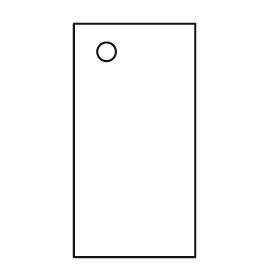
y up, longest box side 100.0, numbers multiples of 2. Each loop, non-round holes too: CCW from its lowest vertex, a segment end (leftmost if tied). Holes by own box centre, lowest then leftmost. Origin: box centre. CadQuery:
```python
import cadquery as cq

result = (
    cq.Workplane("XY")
    .moveTo(-26.0, -50.0)
    .lineTo(26.0, -50.0)
    .lineTo(26.0, 50.0)
    .lineTo(-26.0, 50.0)
    .close()
    .moveTo(-12.0, 38.0)
    .circle(4.0)
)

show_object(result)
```